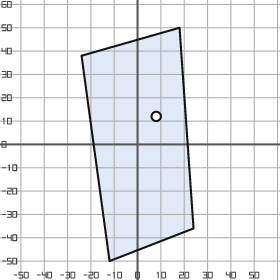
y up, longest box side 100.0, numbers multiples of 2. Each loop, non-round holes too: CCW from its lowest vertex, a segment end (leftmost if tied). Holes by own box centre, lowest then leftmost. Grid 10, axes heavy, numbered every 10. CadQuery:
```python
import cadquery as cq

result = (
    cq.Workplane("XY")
    .moveTo(-12.0, -50.0)
    .lineTo(24.0, -36.0)
    .lineTo(18.0, 50.0)
    .lineTo(-24.0, 38.0)
    .close()
    .moveTo(8.0, 12.0)
    .circle(2.0)
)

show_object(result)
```